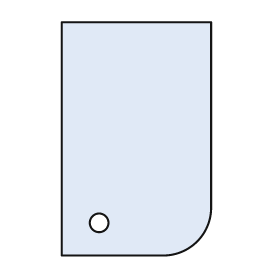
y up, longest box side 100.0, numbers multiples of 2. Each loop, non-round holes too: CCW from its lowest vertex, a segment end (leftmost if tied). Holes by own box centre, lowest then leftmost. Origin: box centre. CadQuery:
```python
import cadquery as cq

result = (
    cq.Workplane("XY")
    .moveTo(-32.0, -50.0)
    .lineTo(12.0, -50.0)
    .threePointArc((26.0, -44.0), (32.0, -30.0))
    .lineTo(32.0, 50.0)
    .lineTo(-32.0, 50.0)
    .close()
    .moveTo(-16.0, -36.0)
    .circle(4.0)
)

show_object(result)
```